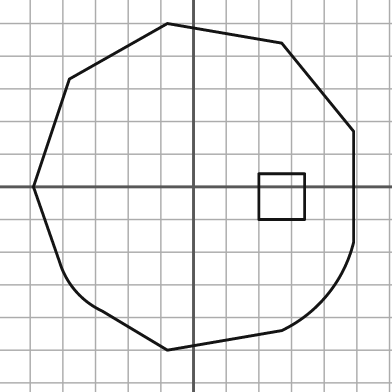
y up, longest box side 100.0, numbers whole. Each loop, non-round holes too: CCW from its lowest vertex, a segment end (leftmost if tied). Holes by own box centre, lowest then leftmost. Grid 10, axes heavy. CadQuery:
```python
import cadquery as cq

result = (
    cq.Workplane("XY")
    .moveTo(-8.0, -50.0)
    .lineTo(27.0, -44.0)
    .threePointArc((41.0, -33.0), (49.0, -17.0))
    .lineTo(49.0, 17.0)
    .lineTo(27.0, 44.0)
    .lineTo(-8.0, 50.0)
    .lineTo(-38.0, 33.0)
    .lineTo(-49.0, 0.0)
    .lineTo(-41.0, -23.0)
    .threePointArc((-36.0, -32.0), (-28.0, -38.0))
    .close()
    .moveTo(20.0, -10.0)
    .lineTo(34.0, -10.0)
    .lineTo(34.0, 4.0)
    .lineTo(20.0, 4.0)
    .close()
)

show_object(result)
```